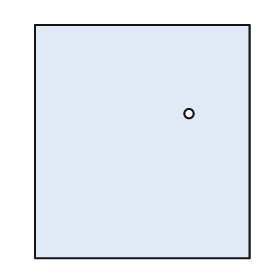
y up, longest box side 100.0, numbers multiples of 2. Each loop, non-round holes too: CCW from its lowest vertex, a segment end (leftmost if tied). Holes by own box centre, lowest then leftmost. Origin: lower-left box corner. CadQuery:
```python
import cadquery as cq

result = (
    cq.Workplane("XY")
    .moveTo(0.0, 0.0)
    .lineTo(92.0, 0.0)
    .lineTo(92.0, 100.0)
    .lineTo(0.0, 100.0)
    .close()
    .moveTo(66.0, 62.0)
    .circle(2.0)
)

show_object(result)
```